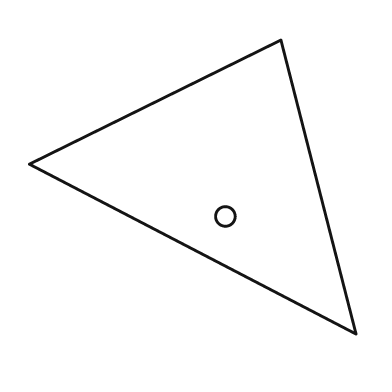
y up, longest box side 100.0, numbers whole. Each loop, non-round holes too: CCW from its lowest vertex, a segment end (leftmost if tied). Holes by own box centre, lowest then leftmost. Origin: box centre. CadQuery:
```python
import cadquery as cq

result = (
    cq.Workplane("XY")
    .moveTo(50.0, -45.0)
    .lineTo(27.0, 45.0)
    .lineTo(-50.0, 7.0)
    .close()
    .moveTo(10.0, -9.0)
    .circle(3.0)
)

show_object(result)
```